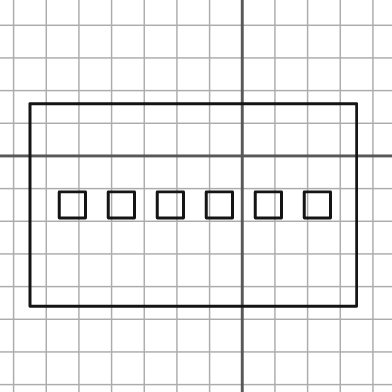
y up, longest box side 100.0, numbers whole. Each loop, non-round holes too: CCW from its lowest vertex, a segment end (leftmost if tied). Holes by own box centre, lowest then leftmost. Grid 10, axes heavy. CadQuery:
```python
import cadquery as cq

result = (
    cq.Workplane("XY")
    .moveTo(-65.0, -46.0)
    .lineTo(35.0, -46.0)
    .lineTo(35.0, 16.0)
    .lineTo(-65.0, 16.0)
    .close()
    .moveTo(-56.0, -19.0)
    .lineTo(-48.0, -19.0)
    .lineTo(-48.0, -11.0)
    .lineTo(-56.0, -11.0)
    .close()
    .moveTo(-41.0, -19.0)
    .lineTo(-33.0, -19.0)
    .lineTo(-33.0, -11.0)
    .lineTo(-41.0, -11.0)
    .close()
    .moveTo(-26.0, -19.0)
    .lineTo(-18.0, -19.0)
    .lineTo(-18.0, -11.0)
    .lineTo(-26.0, -11.0)
    .close()
    .moveTo(-11.0, -19.0)
    .lineTo(-3.0, -19.0)
    .lineTo(-3.0, -11.0)
    .lineTo(-11.0, -11.0)
    .close()
    .moveTo(4.0, -19.0)
    .lineTo(12.0, -19.0)
    .lineTo(12.0, -11.0)
    .lineTo(4.0, -11.0)
    .close()
    .moveTo(19.0, -19.0)
    .lineTo(27.0, -19.0)
    .lineTo(27.0, -11.0)
    .lineTo(19.0, -11.0)
    .close()
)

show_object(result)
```